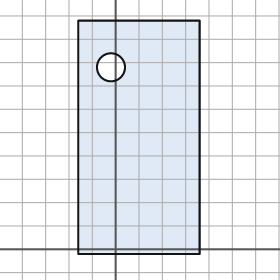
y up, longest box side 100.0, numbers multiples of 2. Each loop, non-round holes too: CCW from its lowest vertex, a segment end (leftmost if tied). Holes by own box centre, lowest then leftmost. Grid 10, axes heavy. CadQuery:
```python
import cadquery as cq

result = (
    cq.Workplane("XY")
    .moveTo(-16.0, -2.0)
    .lineTo(36.0, -2.0)
    .lineTo(36.0, 98.0)
    .lineTo(-16.0, 98.0)
    .close()
    .moveTo(-2.0, 78.0)
    .circle(6.0)
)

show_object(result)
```